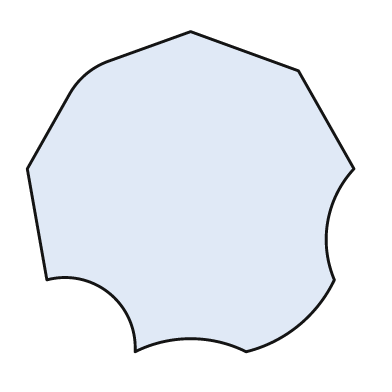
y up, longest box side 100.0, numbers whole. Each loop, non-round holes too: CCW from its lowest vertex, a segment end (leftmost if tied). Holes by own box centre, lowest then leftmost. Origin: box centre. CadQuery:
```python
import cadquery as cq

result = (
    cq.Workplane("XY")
    .moveTo(-17.0, -49.0)
    .threePointArc((0.0, -45.0), (17.0, -49.0))
    .threePointArc((33.0, -41.0), (44.0, -27.0))
    .threePointArc((42.0, -9.0), (50.0, 7.0))
    .lineTo(33.0, 37.0)
    .lineTo(0.0, 49.0)
    .lineTo(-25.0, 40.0)
    .threePointArc((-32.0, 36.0), (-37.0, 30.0))
    .lineTo(-50.0, 7.0)
    .lineTo(-44.0, -27.0)
    .threePointArc((-25.0, -31.0), (-17.0, -49.0))
    .close()
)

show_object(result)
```